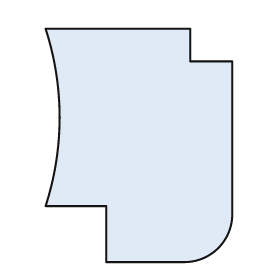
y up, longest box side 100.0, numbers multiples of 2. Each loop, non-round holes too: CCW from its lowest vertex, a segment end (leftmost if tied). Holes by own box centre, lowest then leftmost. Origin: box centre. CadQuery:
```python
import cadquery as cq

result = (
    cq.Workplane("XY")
    .moveTo(-14.0, -50.0)
    .lineTo(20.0, -50.0)
    .threePointArc((34.0, -44.0), (40.0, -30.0))
    .lineTo(40.0, 36.0)
    .lineTo(22.0, 36.0)
    .lineTo(22.0, 50.0)
    .lineTo(-40.0, 50.0)
    .threePointArc((-34.0, 12.0), (-40.0, -26.0))
    .lineTo(-14.0, -26.0)
    .close()
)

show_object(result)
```